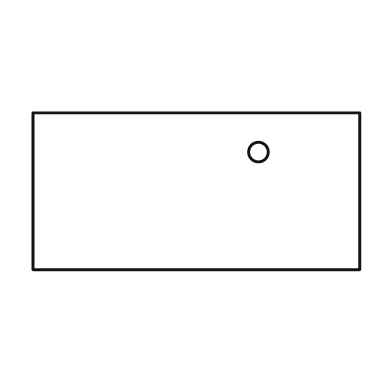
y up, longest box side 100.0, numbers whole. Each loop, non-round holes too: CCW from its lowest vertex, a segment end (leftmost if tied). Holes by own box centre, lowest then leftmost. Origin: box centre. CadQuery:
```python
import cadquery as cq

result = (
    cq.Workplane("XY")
    .moveTo(-50.0, -24.0)
    .lineTo(50.0, -24.0)
    .lineTo(50.0, 24.0)
    .lineTo(-50.0, 24.0)
    .close()
    .moveTo(19.0, 12.0)
    .circle(3.0)
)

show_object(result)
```